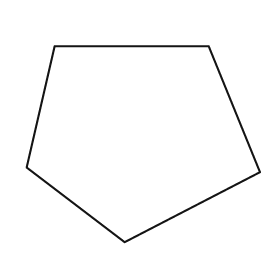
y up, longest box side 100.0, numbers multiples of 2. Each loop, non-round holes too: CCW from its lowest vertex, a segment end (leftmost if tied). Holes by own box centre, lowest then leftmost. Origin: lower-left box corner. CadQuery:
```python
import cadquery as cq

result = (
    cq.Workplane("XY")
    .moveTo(42.0, 0.0)
    .lineTo(100.0, 30.0)
    .lineTo(78.0, 84.0)
    .lineTo(12.0, 84.0)
    .lineTo(0.0, 32.0)
    .close()
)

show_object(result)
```